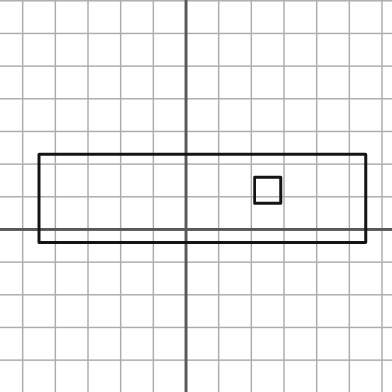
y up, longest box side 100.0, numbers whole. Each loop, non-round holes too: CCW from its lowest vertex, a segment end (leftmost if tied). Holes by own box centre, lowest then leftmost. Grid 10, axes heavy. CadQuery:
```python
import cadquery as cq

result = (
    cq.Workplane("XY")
    .moveTo(-45.0, -4.0)
    .lineTo(55.0, -4.0)
    .lineTo(55.0, 23.0)
    .lineTo(-45.0, 23.0)
    .close()
    .moveTo(21.0, 8.0)
    .lineTo(29.0, 8.0)
    .lineTo(29.0, 16.0)
    .lineTo(21.0, 16.0)
    .close()
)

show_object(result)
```